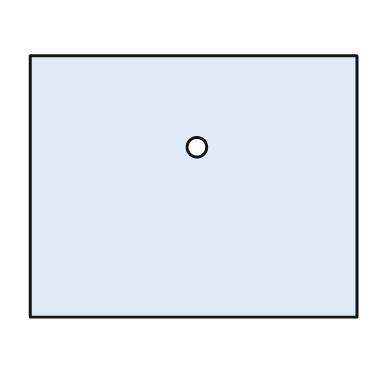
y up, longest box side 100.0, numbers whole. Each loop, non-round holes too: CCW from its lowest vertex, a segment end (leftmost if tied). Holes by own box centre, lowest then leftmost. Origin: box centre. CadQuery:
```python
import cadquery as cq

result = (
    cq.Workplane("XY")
    .moveTo(-50.0, -40.0)
    .lineTo(50.0, -40.0)
    .lineTo(50.0, 40.0)
    .lineTo(-50.0, 40.0)
    .close()
    .moveTo(1.0, 12.0)
    .circle(3.0)
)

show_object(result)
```